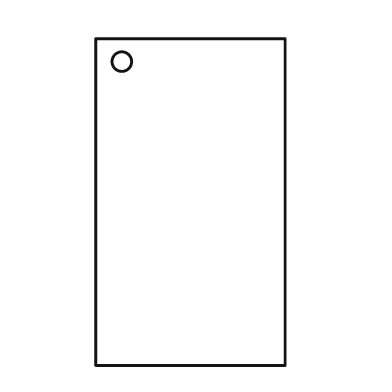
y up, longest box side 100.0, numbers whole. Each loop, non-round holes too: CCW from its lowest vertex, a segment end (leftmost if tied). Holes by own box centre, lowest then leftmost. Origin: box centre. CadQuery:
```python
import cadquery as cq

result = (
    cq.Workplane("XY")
    .moveTo(-29.0, -50.0)
    .lineTo(29.0, -50.0)
    .lineTo(29.0, 50.0)
    .lineTo(-29.0, 50.0)
    .close()
    .moveTo(-21.0, 43.0)
    .circle(3.0)
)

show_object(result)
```